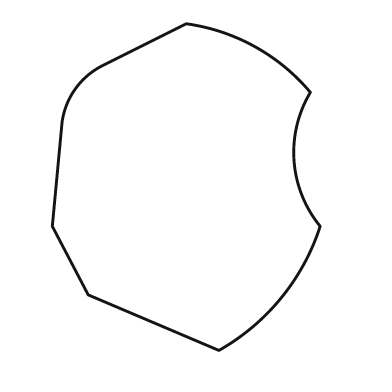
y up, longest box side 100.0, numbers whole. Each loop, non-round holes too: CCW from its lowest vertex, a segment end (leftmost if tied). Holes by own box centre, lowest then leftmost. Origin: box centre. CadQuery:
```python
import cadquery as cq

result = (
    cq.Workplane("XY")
    .moveTo(10.0, -50.0)
    .threePointArc((29.0, -34.0), (41.0, -12.0))
    .threePointArc((33.0, 8.0), (38.0, 29.0))
    .threePointArc((21.0, 43.0), (0.0, 50.0))
    .lineTo(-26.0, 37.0)
    .threePointArc((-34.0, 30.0), (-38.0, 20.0))
    .lineTo(-41.0, -12.0)
    .lineTo(-30.0, -33.0)
    .close()
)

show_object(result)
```